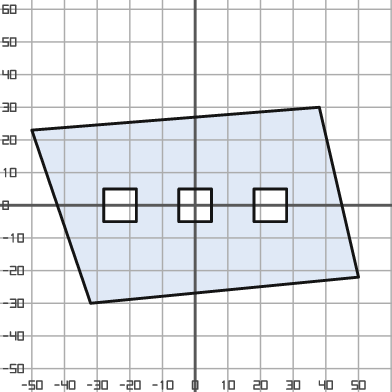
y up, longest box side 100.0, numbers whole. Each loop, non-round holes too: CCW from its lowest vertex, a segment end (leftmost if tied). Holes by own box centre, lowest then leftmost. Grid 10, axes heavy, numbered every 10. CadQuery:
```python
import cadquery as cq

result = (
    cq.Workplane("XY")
    .moveTo(-32.0, -30.0)
    .lineTo(50.0, -22.0)
    .lineTo(38.0, 30.0)
    .lineTo(-50.0, 23.0)
    .close()
    .moveTo(-28.0, -5.0)
    .lineTo(-18.0, -5.0)
    .lineTo(-18.0, 5.0)
    .lineTo(-28.0, 5.0)
    .close()
    .moveTo(-5.0, -5.0)
    .lineTo(5.0, -5.0)
    .lineTo(5.0, 5.0)
    .lineTo(-5.0, 5.0)
    .close()
    .moveTo(18.0, -5.0)
    .lineTo(28.0, -5.0)
    .lineTo(28.0, 5.0)
    .lineTo(18.0, 5.0)
    .close()
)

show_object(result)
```